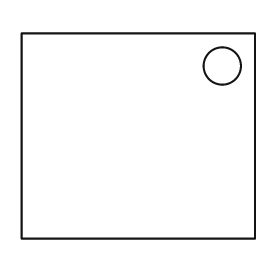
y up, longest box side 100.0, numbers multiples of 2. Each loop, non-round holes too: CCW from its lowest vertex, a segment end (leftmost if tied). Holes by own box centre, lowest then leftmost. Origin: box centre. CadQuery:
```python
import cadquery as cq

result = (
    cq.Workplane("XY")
    .moveTo(-50.0, -44.0)
    .lineTo(50.0, -44.0)
    .lineTo(50.0, 44.0)
    .lineTo(-50.0, 44.0)
    .close()
    .moveTo(36.0, 30.0)
    .circle(8.0)
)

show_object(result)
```